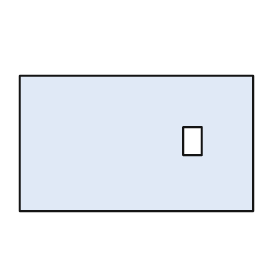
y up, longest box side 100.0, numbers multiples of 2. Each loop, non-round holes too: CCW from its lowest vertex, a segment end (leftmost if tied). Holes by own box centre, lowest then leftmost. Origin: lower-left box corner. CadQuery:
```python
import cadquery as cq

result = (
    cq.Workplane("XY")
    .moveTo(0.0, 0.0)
    .lineTo(100.0, 0.0)
    .lineTo(100.0, 58.0)
    .lineTo(0.0, 58.0)
    .close()
    .moveTo(70.0, 24.0)
    .lineTo(78.0, 24.0)
    .lineTo(78.0, 36.0)
    .lineTo(70.0, 36.0)
    .close()
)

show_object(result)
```